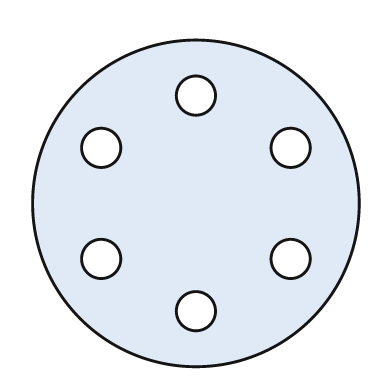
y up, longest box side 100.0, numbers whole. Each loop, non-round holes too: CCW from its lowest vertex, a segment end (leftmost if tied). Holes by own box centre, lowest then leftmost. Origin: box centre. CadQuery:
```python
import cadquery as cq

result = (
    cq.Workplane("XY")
    .moveTo(0.0, 0.0)
    .circle(50.0)
    .moveTo(0.0, -33.0)
    .circle(6.0)
    .moveTo(-29.0, -17.0)
    .circle(6.0)
    .moveTo(29.0, -17.0)
    .circle(6.0)
    .moveTo(-29.0, 17.0)
    .circle(6.0)
    .moveTo(29.0, 17.0)
    .circle(6.0)
    .moveTo(0.0, 33.0)
    .circle(6.0)
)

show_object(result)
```